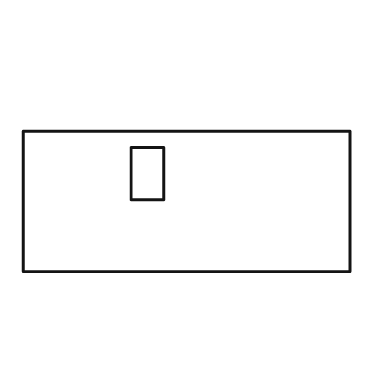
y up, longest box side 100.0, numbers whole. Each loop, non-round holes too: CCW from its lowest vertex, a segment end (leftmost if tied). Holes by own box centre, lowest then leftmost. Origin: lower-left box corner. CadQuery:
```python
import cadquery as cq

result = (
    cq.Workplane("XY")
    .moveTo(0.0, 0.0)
    .lineTo(100.0, 0.0)
    .lineTo(100.0, 43.0)
    .lineTo(0.0, 43.0)
    .close()
    .moveTo(33.0, 22.0)
    .lineTo(43.0, 22.0)
    .lineTo(43.0, 38.0)
    .lineTo(33.0, 38.0)
    .close()
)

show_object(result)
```